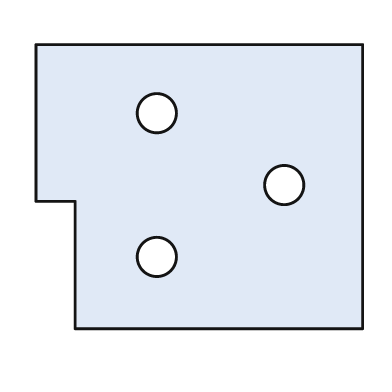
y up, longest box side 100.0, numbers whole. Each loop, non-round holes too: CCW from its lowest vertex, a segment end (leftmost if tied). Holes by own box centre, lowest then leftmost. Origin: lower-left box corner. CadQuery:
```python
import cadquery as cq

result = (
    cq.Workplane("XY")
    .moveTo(12.0, 0.0)
    .lineTo(100.0, 0.0)
    .lineTo(100.0, 87.0)
    .lineTo(0.0, 87.0)
    .lineTo(0.0, 39.0)
    .lineTo(12.0, 39.0)
    .close()
    .moveTo(37.0, 22.0)
    .circle(6.0)
    .moveTo(76.0, 44.0)
    .circle(6.0)
    .moveTo(37.0, 66.0)
    .circle(6.0)
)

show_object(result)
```